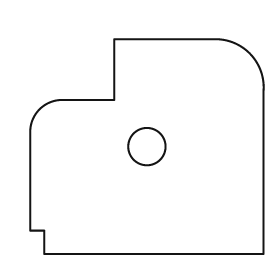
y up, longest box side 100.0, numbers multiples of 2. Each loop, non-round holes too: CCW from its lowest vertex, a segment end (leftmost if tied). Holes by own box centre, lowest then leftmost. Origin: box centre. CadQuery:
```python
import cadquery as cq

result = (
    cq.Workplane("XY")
    .moveTo(-44.0, -46.0)
    .lineTo(50.0, -46.0)
    .lineTo(50.0, 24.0)
    .threePointArc((44.0, 40.0), (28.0, 46.0))
    .lineTo(-14.0, 46.0)
    .lineTo(-14.0, 20.0)
    .lineTo(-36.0, 20.0)
    .threePointArc((-46.0, 16.0), (-50.0, 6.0))
    .lineTo(-50.0, -36.0)
    .lineTo(-44.0, -36.0)
    .close()
    .moveTo(0.0, 0.0)
    .circle(8.0)
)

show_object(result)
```